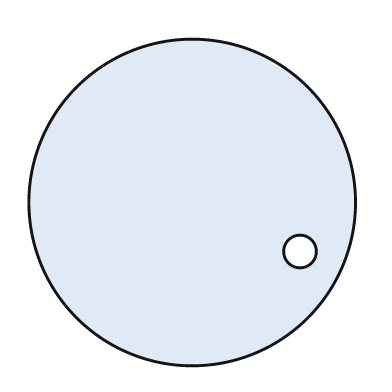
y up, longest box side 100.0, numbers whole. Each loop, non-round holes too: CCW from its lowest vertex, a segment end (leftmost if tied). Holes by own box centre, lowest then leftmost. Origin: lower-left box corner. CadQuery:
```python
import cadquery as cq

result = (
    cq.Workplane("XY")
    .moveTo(50.0, 50.0)
    .circle(50.0)
    .moveTo(83.0, 35.0)
    .circle(5.0)
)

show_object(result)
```